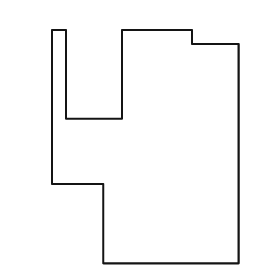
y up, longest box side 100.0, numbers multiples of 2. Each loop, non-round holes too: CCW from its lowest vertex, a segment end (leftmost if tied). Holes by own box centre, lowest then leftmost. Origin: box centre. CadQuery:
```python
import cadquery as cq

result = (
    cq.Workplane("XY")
    .moveTo(-18.0, -50.0)
    .lineTo(40.0, -50.0)
    .lineTo(40.0, 44.0)
    .lineTo(20.0, 44.0)
    .lineTo(20.0, 50.0)
    .lineTo(-10.0, 50.0)
    .lineTo(-10.0, 12.0)
    .lineTo(-34.0, 12.0)
    .lineTo(-34.0, 50.0)
    .lineTo(-40.0, 50.0)
    .lineTo(-40.0, -16.0)
    .lineTo(-18.0, -16.0)
    .close()
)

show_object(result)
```